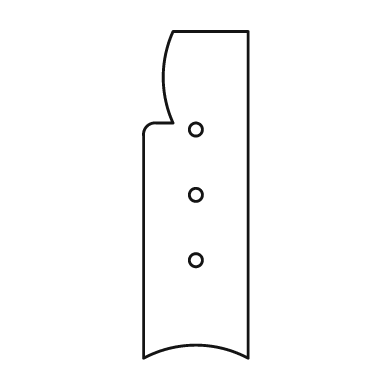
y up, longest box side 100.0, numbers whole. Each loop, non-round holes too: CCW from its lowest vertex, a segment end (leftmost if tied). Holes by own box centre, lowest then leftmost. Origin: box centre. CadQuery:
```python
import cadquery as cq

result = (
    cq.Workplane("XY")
    .moveTo(-16.0, -50.0)
    .threePointArc((0.0, -46.0), (16.0, -50.0))
    .lineTo(16.0, 50.0)
    .lineTo(-7.0, 50.0)
    .threePointArc((-10.0, 36.0), (-7.0, 22.0))
    .lineTo(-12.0, 22.0)
    .threePointArc((-15.0, 21.0), (-16.0, 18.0))
    .close()
    .moveTo(0.0, -20.0)
    .circle(2.0)
    .moveTo(0.0, 0.0)
    .circle(2.0)
    .moveTo(0.0, 20.0)
    .circle(2.0)
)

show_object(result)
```